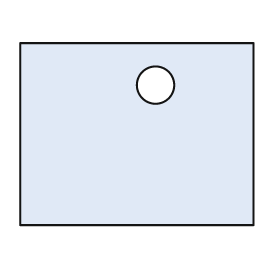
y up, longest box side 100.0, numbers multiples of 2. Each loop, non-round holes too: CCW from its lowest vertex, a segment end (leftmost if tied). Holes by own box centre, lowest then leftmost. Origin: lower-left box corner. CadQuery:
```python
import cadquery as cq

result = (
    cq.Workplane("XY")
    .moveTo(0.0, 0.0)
    .lineTo(100.0, 0.0)
    .lineTo(100.0, 78.0)
    .lineTo(0.0, 78.0)
    .close()
    .moveTo(58.0, 60.0)
    .circle(8.0)
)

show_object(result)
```